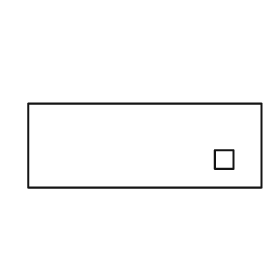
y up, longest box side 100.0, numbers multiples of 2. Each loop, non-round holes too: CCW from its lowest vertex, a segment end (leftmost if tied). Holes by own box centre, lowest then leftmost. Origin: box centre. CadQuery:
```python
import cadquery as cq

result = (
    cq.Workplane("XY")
    .moveTo(-50.0, -18.0)
    .lineTo(50.0, -18.0)
    .lineTo(50.0, 18.0)
    .lineTo(-50.0, 18.0)
    .close()
    .moveTo(30.0, -10.0)
    .lineTo(38.0, -10.0)
    .lineTo(38.0, -2.0)
    .lineTo(30.0, -2.0)
    .close()
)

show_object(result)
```